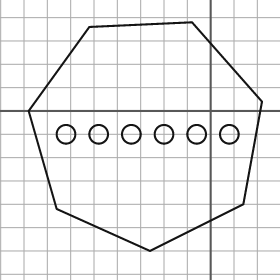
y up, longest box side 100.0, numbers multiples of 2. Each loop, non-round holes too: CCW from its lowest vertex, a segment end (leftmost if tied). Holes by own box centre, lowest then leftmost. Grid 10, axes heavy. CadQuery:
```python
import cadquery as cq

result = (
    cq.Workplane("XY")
    .moveTo(-26.0, -60.0)
    .lineTo(14.0, -40.0)
    .lineTo(22.0, 4.0)
    .lineTo(-8.0, 38.0)
    .lineTo(-52.0, 36.0)
    .lineTo(-78.0, 0.0)
    .lineTo(-66.0, -42.0)
    .close()
    .moveTo(-62.0, -10.0)
    .circle(4.0)
    .moveTo(-48.0, -10.0)
    .circle(4.0)
    .moveTo(-34.0, -10.0)
    .circle(4.0)
    .moveTo(-20.0, -10.0)
    .circle(4.0)
    .moveTo(-6.0, -10.0)
    .circle(4.0)
    .moveTo(8.0, -10.0)
    .circle(4.0)
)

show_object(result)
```